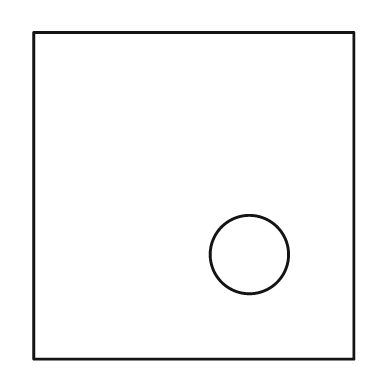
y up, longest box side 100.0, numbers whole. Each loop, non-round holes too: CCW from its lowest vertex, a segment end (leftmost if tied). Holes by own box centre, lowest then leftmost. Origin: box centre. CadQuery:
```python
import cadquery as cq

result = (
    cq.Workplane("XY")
    .moveTo(-49.0, -50.0)
    .lineTo(49.0, -50.0)
    .lineTo(49.0, 50.0)
    .lineTo(-49.0, 50.0)
    .close()
    .moveTo(17.0, -18.0)
    .circle(12.0)
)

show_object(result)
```